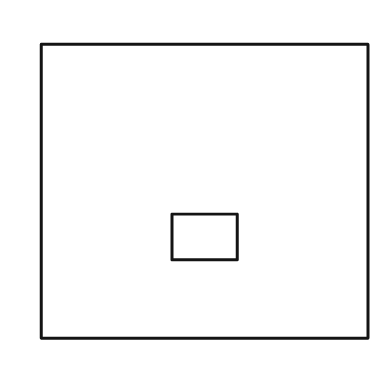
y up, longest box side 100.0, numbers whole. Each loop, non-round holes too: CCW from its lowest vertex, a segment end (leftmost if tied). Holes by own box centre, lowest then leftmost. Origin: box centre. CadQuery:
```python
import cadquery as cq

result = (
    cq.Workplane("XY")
    .moveTo(-50.0, -45.0)
    .lineTo(50.0, -45.0)
    .lineTo(50.0, 45.0)
    .lineTo(-50.0, 45.0)
    .close()
    .moveTo(-10.0, -21.0)
    .lineTo(10.0, -21.0)
    .lineTo(10.0, -7.0)
    .lineTo(-10.0, -7.0)
    .close()
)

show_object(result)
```